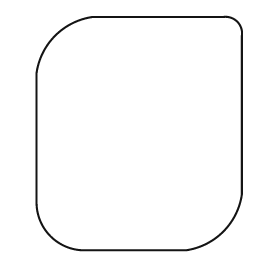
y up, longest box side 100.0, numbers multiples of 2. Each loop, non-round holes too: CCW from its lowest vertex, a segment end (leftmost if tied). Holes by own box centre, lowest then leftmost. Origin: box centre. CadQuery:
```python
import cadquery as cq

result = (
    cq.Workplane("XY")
    .moveTo(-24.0, -50.0)
    .lineTo(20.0, -50.0)
    .threePointArc((36.0, -42.0), (44.0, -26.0))
    .lineTo(44.0, 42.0)
    .threePointArc((42.0, 48.0), (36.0, 50.0))
    .lineTo(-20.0, 50.0)
    .threePointArc((-36.0, 42.0), (-44.0, 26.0))
    .lineTo(-44.0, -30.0)
    .threePointArc((-38.0, -44.0), (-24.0, -50.0))
    .close()
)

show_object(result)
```